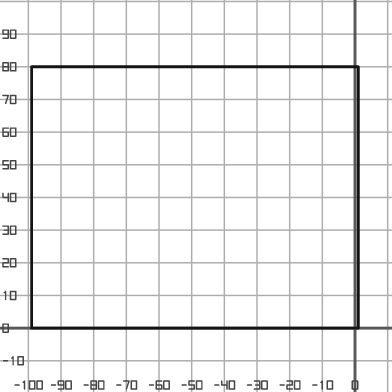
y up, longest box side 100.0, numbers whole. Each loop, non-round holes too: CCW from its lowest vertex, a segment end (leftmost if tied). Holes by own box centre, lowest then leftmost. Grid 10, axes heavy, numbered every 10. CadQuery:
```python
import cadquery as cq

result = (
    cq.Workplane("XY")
    .moveTo(-99.0, 0.0)
    .lineTo(1.0, 0.0)
    .lineTo(1.0, 80.0)
    .lineTo(-99.0, 80.0)
    .close()
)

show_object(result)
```